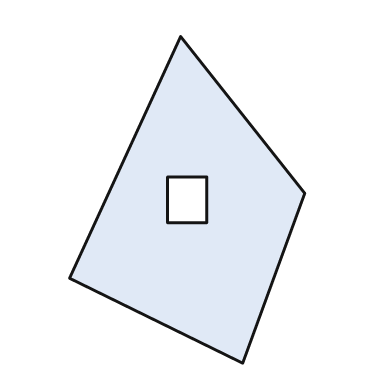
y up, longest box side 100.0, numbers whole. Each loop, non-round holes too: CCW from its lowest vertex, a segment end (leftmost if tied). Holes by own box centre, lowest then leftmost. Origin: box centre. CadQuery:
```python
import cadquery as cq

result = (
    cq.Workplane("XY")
    .moveTo(17.0, -50.0)
    .lineTo(36.0, 2.0)
    .lineTo(-2.0, 50.0)
    .lineTo(-36.0, -24.0)
    .close()
    .moveTo(-6.0, -7.0)
    .lineTo(6.0, -7.0)
    .lineTo(6.0, 7.0)
    .lineTo(-6.0, 7.0)
    .close()
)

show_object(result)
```